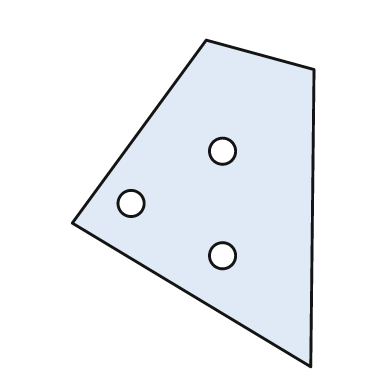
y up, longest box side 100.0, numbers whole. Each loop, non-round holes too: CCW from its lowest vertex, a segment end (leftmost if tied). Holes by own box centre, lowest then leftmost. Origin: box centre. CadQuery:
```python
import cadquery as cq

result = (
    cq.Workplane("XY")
    .moveTo(36.0, -50.0)
    .lineTo(37.0, 41.0)
    .lineTo(4.0, 50.0)
    .lineTo(-37.0, -6.0)
    .close()
    .moveTo(9.0, -16.0)
    .circle(4.0)
    .moveTo(-19.0, 0.0)
    .circle(4.0)
    .moveTo(9.0, 16.0)
    .circle(4.0)
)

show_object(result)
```